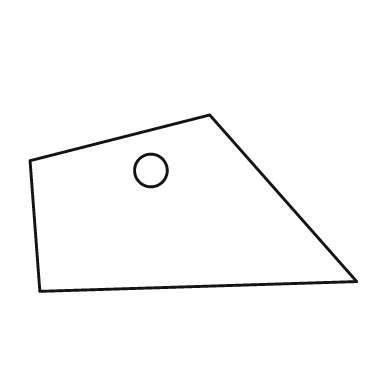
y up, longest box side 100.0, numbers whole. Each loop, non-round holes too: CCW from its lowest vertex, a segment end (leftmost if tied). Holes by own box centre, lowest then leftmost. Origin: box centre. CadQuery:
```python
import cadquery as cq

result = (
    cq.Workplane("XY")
    .moveTo(-47.0, -27.0)
    .lineTo(50.0, -24.0)
    .lineTo(5.0, 27.0)
    .lineTo(-50.0, 13.0)
    .close()
    .moveTo(-13.0, 10.0)
    .circle(5.0)
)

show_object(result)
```